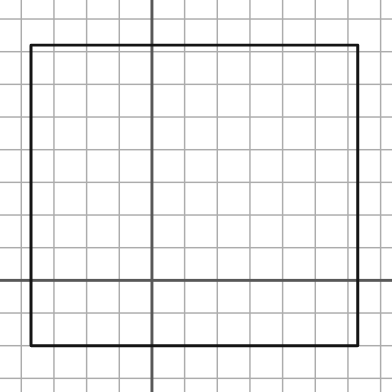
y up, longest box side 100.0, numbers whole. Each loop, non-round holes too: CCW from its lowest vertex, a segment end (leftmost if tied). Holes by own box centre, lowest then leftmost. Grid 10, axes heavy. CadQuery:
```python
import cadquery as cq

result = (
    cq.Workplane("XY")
    .moveTo(-37.0, -20.0)
    .lineTo(63.0, -20.0)
    .lineTo(63.0, 72.0)
    .lineTo(-37.0, 72.0)
    .close()
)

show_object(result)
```